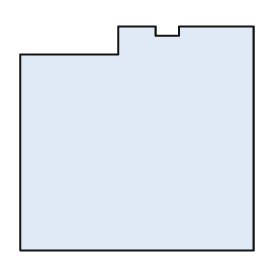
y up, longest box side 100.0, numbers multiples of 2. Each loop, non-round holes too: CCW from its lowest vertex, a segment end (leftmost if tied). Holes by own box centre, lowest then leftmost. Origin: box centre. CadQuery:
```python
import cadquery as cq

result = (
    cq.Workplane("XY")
    .moveTo(-50.0, -48.0)
    .lineTo(50.0, -48.0)
    .lineTo(50.0, 48.0)
    .lineTo(18.0, 48.0)
    .lineTo(18.0, 44.0)
    .lineTo(8.0, 44.0)
    .lineTo(8.0, 48.0)
    .lineTo(-8.0, 48.0)
    .lineTo(-8.0, 36.0)
    .lineTo(-50.0, 36.0)
    .close()
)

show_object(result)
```